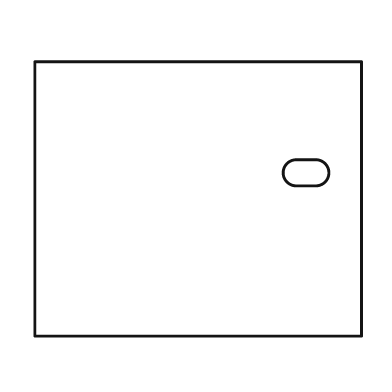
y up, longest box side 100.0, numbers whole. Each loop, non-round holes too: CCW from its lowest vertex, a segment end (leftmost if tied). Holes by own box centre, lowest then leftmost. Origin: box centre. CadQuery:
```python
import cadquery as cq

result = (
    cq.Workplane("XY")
    .moveTo(-50.0, -42.0)
    .lineTo(50.0, -42.0)
    .lineTo(50.0, 42.0)
    .lineTo(-50.0, 42.0)
    .close()
    .moveTo(30.0, 4.0)
    .lineTo(36.0, 4.0)
    .threePointArc((40.0, 8.0), (36.0, 12.0))
    .lineTo(30.0, 12.0)
    .threePointArc((26.0, 8.0), (30.0, 4.0))
    .close()
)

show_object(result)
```